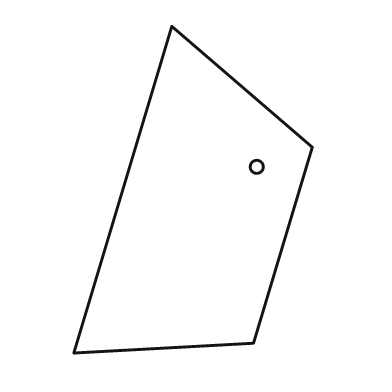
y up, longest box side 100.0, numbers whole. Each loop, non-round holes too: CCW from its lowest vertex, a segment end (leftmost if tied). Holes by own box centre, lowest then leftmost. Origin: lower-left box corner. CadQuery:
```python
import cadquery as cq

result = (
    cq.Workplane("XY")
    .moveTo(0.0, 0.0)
    .lineTo(55.0, 3.0)
    .lineTo(73.0, 63.0)
    .lineTo(30.0, 100.0)
    .close()
    .moveTo(56.0, 57.0)
    .circle(2.0)
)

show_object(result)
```